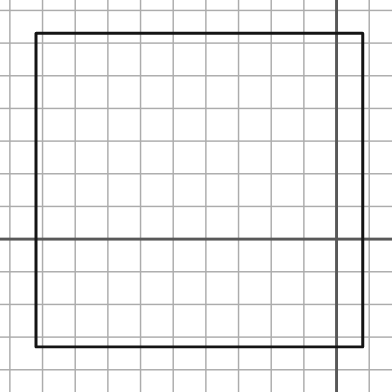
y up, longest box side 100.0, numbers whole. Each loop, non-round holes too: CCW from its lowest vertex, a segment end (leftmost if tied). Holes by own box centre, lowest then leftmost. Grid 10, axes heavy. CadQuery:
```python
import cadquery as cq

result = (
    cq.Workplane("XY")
    .moveTo(-92.0, -33.0)
    .lineTo(8.0, -33.0)
    .lineTo(8.0, 63.0)
    .lineTo(-92.0, 63.0)
    .close()
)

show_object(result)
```